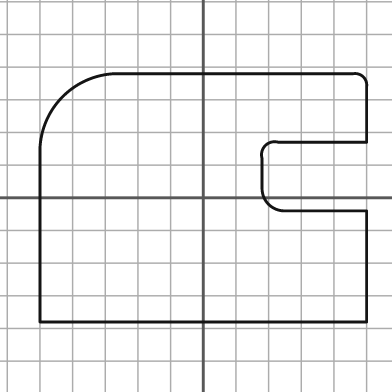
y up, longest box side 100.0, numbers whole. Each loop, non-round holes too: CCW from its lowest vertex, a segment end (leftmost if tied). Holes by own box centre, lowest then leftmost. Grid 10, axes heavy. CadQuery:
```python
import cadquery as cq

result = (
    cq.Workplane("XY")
    .moveTo(-50.0, -38.0)
    .lineTo(50.0, -38.0)
    .lineTo(50.0, -4.0)
    .lineTo(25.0, -4.0)
    .threePointArc((20.0, -2.0), (18.0, 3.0))
    .lineTo(18.0, 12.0)
    .threePointArc((19.0, 16.0), (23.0, 17.0))
    .lineTo(50.0, 17.0)
    .lineTo(50.0, 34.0)
    .threePointArc((49.0, 37.0), (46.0, 38.0))
    .lineTo(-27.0, 38.0)
    .threePointArc((-43.0, 31.0), (-50.0, 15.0))
    .close()
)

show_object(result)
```